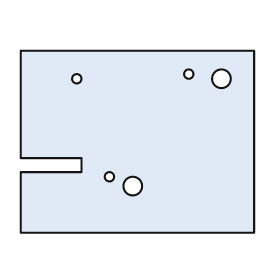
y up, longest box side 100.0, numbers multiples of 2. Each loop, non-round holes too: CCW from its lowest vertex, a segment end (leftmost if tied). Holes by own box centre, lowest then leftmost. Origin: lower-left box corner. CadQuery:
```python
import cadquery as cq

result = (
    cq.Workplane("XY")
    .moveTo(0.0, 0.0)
    .lineTo(100.0, 0.0)
    .lineTo(100.0, 78.0)
    .lineTo(0.0, 78.0)
    .lineTo(0.0, 32.0)
    .lineTo(26.0, 32.0)
    .lineTo(26.0, 26.0)
    .lineTo(0.0, 26.0)
    .close()
    .moveTo(48.0, 20.0)
    .circle(4.0)
    .moveTo(38.0, 24.0)
    .circle(2.0)
    .moveTo(24.0, 66.0)
    .circle(2.0)
    .moveTo(86.0, 66.0)
    .circle(4.0)
    .moveTo(72.0, 68.0)
    .circle(2.0)
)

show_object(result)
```